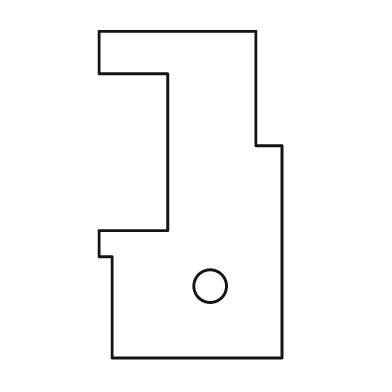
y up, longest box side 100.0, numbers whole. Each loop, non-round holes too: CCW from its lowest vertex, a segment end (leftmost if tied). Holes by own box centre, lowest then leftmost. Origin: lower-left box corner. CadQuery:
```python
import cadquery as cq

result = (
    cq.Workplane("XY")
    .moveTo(4.0, 0.0)
    .lineTo(56.0, 0.0)
    .lineTo(56.0, 65.0)
    .lineTo(48.0, 65.0)
    .lineTo(48.0, 100.0)
    .lineTo(0.0, 100.0)
    .lineTo(0.0, 87.0)
    .lineTo(21.0, 87.0)
    .lineTo(21.0, 39.0)
    .lineTo(0.0, 39.0)
    .lineTo(0.0, 31.0)
    .lineTo(4.0, 31.0)
    .close()
    .moveTo(34.0, 22.0)
    .circle(5.0)
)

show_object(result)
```